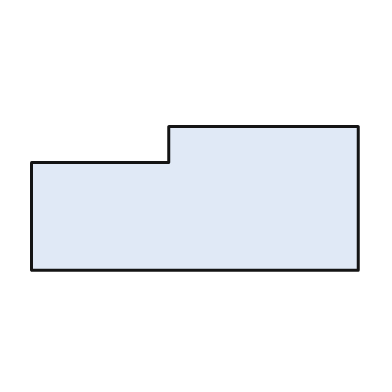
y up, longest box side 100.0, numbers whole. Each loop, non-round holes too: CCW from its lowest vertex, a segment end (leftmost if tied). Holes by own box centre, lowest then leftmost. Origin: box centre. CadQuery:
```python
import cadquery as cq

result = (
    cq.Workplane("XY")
    .moveTo(-50.0, -22.0)
    .lineTo(50.0, -22.0)
    .lineTo(50.0, 22.0)
    .lineTo(-8.0, 22.0)
    .lineTo(-8.0, 11.0)
    .lineTo(-50.0, 11.0)
    .close()
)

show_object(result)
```